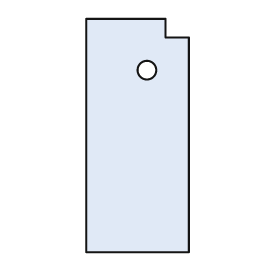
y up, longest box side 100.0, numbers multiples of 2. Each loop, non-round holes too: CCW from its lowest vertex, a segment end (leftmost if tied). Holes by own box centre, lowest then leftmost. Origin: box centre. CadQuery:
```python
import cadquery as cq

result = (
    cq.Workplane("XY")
    .moveTo(-22.0, -50.0)
    .lineTo(22.0, -50.0)
    .lineTo(22.0, 42.0)
    .lineTo(12.0, 42.0)
    .lineTo(12.0, 50.0)
    .lineTo(-22.0, 50.0)
    .close()
    .moveTo(4.0, 28.0)
    .circle(4.0)
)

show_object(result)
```